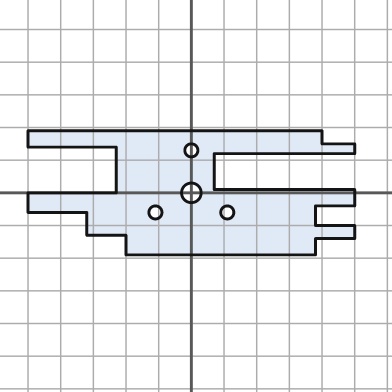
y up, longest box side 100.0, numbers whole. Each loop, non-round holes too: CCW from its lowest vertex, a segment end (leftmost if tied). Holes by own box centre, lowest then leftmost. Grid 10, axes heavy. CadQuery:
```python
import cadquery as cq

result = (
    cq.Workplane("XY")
    .moveTo(-20.0, -19.0)
    .lineTo(38.0, -19.0)
    .lineTo(38.0, -14.0)
    .lineTo(50.0, -14.0)
    .lineTo(50.0, -10.0)
    .lineTo(38.0, -10.0)
    .lineTo(38.0, -4.0)
    .lineTo(50.0, -4.0)
    .lineTo(50.0, 1.0)
    .lineTo(7.0, 1.0)
    .lineTo(7.0, 12.0)
    .lineTo(50.0, 12.0)
    .lineTo(50.0, 15.0)
    .lineTo(40.0, 15.0)
    .lineTo(40.0, 19.0)
    .lineTo(-50.0, 19.0)
    .lineTo(-50.0, 14.0)
    .lineTo(-23.0, 14.0)
    .lineTo(-23.0, 0.0)
    .lineTo(-50.0, 0.0)
    .lineTo(-50.0, -6.0)
    .lineTo(-32.0, -6.0)
    .lineTo(-32.0, -13.0)
    .lineTo(-20.0, -13.0)
    .close()
    .moveTo(-11.0, -6.0)
    .circle(2.0)
    .moveTo(11.0, -6.0)
    .circle(2.0)
    .moveTo(0.0, 0.0)
    .circle(3.0)
    .moveTo(0.0, 13.0)
    .circle(2.0)
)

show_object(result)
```